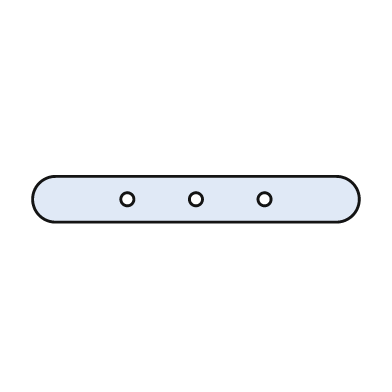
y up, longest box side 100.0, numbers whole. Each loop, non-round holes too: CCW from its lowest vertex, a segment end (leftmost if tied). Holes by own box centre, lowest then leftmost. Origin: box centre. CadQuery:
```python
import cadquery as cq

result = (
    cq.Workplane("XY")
    .moveTo(-43.0, -7.0)
    .lineTo(43.0, -7.0)
    .threePointArc((50.0, 0.0), (43.0, 7.0))
    .lineTo(-43.0, 7.0)
    .threePointArc((-50.0, 0.0), (-43.0, -7.0))
    .close()
    .moveTo(-21.0, 0.0)
    .circle(2.0)
    .moveTo(0.0, 0.0)
    .circle(2.0)
    .moveTo(21.0, 0.0)
    .circle(2.0)
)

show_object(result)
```